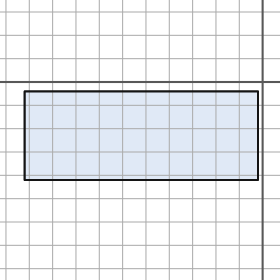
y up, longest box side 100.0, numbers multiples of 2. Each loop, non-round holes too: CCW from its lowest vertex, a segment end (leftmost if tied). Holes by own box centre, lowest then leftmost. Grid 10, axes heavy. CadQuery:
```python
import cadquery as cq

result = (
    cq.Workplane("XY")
    .moveTo(-102.0, -42.0)
    .lineTo(-2.0, -42.0)
    .lineTo(-2.0, -4.0)
    .lineTo(-102.0, -4.0)
    .close()
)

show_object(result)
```